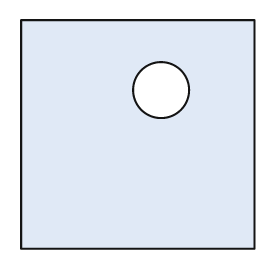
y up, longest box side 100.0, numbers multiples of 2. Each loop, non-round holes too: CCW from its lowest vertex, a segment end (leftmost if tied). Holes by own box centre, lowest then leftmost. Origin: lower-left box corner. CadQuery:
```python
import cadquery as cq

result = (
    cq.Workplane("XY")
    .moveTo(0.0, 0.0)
    .lineTo(100.0, 0.0)
    .lineTo(100.0, 98.0)
    .lineTo(0.0, 98.0)
    .close()
    .moveTo(60.0, 68.0)
    .circle(12.0)
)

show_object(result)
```